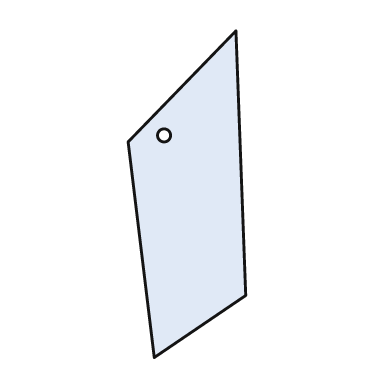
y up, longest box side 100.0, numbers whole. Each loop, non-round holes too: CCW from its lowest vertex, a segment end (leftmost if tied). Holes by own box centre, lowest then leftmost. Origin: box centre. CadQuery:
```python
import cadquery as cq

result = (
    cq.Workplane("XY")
    .moveTo(-10.0, -50.0)
    .lineTo(18.0, -31.0)
    .lineTo(15.0, 50.0)
    .lineTo(-18.0, 16.0)
    .close()
    .moveTo(-7.0, 18.0)
    .circle(2.0)
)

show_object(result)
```